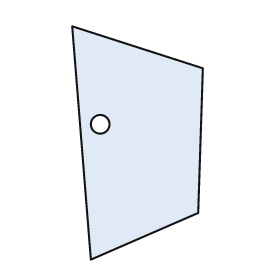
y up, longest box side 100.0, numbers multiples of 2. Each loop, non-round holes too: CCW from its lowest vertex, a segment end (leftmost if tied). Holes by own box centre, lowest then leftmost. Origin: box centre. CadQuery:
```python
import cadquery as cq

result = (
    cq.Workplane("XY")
    .moveTo(-20.0, -50.0)
    .lineTo(26.0, -30.0)
    .lineTo(28.0, 32.0)
    .lineTo(-28.0, 50.0)
    .close()
    .moveTo(-16.0, 8.0)
    .circle(4.0)
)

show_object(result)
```